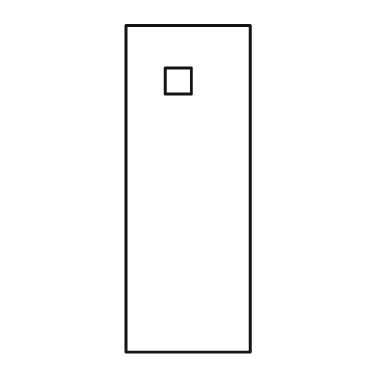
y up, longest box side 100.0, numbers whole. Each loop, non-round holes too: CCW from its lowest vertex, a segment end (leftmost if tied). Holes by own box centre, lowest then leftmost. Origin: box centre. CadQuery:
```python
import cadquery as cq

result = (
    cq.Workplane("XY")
    .moveTo(-19.0, -50.0)
    .lineTo(19.0, -50.0)
    .lineTo(19.0, 50.0)
    .lineTo(-19.0, 50.0)
    .close()
    .moveTo(-7.0, 29.0)
    .lineTo(1.0, 29.0)
    .lineTo(1.0, 37.0)
    .lineTo(-7.0, 37.0)
    .close()
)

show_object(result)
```